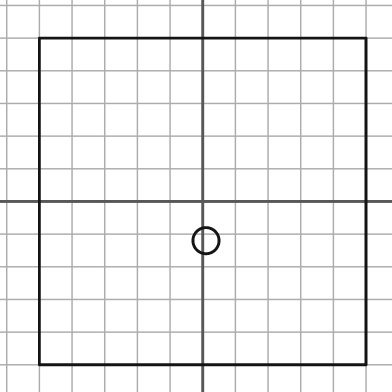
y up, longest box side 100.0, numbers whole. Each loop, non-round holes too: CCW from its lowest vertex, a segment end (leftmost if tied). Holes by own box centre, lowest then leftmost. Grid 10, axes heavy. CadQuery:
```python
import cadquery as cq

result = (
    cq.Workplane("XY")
    .moveTo(-50.0, -50.0)
    .lineTo(50.0, -50.0)
    .lineTo(50.0, 50.0)
    .lineTo(-50.0, 50.0)
    .close()
    .moveTo(1.0, -12.0)
    .circle(4.0)
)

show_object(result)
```